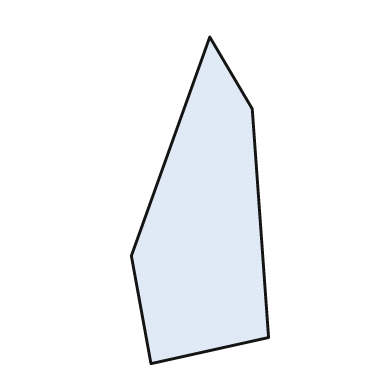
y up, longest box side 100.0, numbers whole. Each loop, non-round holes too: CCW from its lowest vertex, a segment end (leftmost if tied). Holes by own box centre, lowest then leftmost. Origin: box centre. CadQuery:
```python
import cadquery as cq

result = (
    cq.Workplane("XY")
    .moveTo(-15.0, -50.0)
    .lineTo(21.0, -42.0)
    .lineTo(16.0, 28.0)
    .lineTo(3.0, 50.0)
    .lineTo(-21.0, -17.0)
    .close()
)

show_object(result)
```